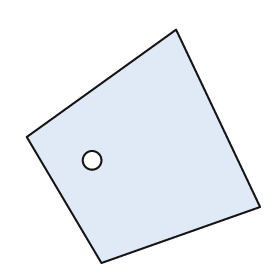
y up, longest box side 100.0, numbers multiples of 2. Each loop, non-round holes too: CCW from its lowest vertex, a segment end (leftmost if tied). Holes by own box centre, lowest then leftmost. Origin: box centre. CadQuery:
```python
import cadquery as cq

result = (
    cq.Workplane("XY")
    .moveTo(-18.0, -50.0)
    .lineTo(50.0, -26.0)
    .lineTo(14.0, 50.0)
    .lineTo(-50.0, 4.0)
    .close()
    .moveTo(-22.0, -6.0)
    .circle(4.0)
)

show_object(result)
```